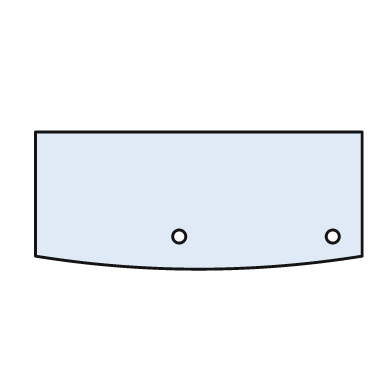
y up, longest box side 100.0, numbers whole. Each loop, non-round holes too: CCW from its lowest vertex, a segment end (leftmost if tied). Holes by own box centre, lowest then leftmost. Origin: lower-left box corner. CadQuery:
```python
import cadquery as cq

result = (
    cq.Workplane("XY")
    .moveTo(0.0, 4.0)
    .threePointArc((50.0, 0.0), (100.0, 4.0))
    .lineTo(100.0, 42.0)
    .lineTo(0.0, 42.0)
    .close()
    .moveTo(44.0, 10.0)
    .circle(2.0)
    .moveTo(91.0, 10.0)
    .circle(2.0)
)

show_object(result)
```